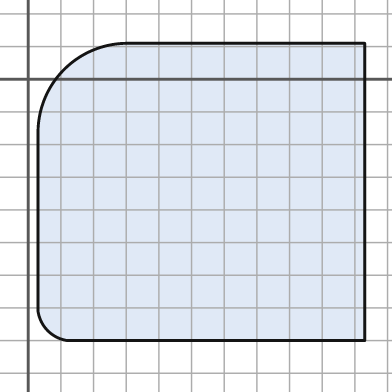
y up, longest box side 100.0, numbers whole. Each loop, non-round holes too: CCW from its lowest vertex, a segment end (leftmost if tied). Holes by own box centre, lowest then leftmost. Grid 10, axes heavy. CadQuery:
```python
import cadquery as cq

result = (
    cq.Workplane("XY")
    .moveTo(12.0, -80.0)
    .lineTo(103.0, -80.0)
    .lineTo(103.0, 11.0)
    .lineTo(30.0, 11.0)
    .threePointArc((11.0, 3.0), (3.0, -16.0))
    .lineTo(3.0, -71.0)
    .threePointArc((6.0, -77.0), (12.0, -80.0))
    .close()
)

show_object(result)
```